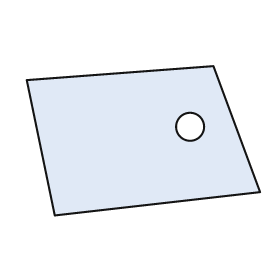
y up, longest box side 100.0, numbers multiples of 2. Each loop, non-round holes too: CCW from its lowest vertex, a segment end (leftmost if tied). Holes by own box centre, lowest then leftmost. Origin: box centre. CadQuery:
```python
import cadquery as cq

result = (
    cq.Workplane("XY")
    .moveTo(-38.0, -32.0)
    .lineTo(50.0, -22.0)
    .lineTo(30.0, 32.0)
    .lineTo(-50.0, 26.0)
    .close()
    .moveTo(20.0, 6.0)
    .circle(6.0)
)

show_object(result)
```